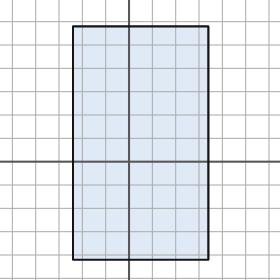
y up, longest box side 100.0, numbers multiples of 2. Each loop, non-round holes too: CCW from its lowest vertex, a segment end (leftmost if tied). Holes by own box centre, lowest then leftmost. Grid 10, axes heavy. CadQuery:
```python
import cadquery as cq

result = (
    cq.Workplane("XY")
    .moveTo(-24.0, -42.0)
    .lineTo(34.0, -42.0)
    .lineTo(34.0, 58.0)
    .lineTo(-24.0, 58.0)
    .close()
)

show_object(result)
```